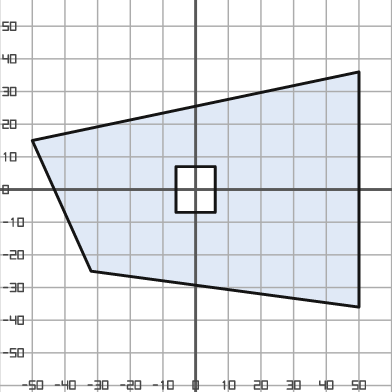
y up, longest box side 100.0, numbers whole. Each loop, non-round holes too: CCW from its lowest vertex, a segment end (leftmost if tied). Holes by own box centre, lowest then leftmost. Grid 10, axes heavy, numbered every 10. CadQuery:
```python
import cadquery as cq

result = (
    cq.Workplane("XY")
    .moveTo(50.0, -36.0)
    .lineTo(50.0, 36.0)
    .lineTo(-50.0, 15.0)
    .lineTo(-32.0, -25.0)
    .close()
    .moveTo(-6.0, -7.0)
    .lineTo(6.0, -7.0)
    .lineTo(6.0, 7.0)
    .lineTo(-6.0, 7.0)
    .close()
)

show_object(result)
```